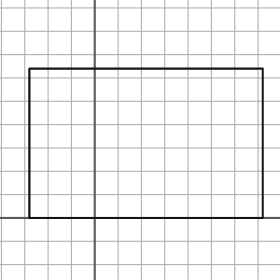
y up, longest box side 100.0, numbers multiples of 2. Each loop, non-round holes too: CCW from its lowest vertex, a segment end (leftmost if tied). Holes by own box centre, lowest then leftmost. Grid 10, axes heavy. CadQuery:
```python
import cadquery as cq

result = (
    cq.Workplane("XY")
    .moveTo(-28.0, 0.0)
    .lineTo(72.0, 0.0)
    .lineTo(72.0, 64.0)
    .lineTo(-28.0, 64.0)
    .close()
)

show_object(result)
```